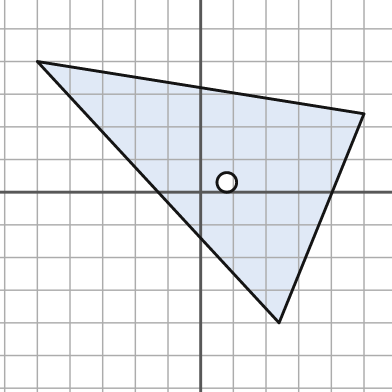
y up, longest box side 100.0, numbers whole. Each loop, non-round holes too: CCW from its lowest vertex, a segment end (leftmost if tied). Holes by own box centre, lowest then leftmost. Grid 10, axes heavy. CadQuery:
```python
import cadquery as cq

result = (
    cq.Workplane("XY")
    .moveTo(24.0, -40.0)
    .lineTo(50.0, 24.0)
    .lineTo(-50.0, 40.0)
    .close()
    .moveTo(8.0, 3.0)
    .circle(3.0)
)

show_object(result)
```